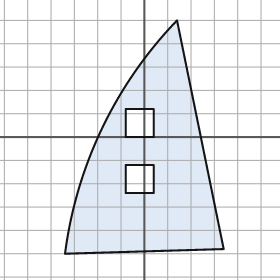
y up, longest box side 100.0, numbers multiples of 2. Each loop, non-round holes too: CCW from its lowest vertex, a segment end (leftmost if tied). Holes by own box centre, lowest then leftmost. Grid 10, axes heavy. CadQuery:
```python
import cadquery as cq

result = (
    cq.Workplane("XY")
    .moveTo(-34.0, -50.0)
    .lineTo(34.0, -48.0)
    .lineTo(14.0, 50.0)
    .threePointArc((-18.0, 4.0), (-34.0, -50.0))
    .close()
    .moveTo(-8.0, -24.0)
    .lineTo(4.0, -24.0)
    .lineTo(4.0, -12.0)
    .lineTo(-8.0, -12.0)
    .close()
    .moveTo(-8.0, 0.0)
    .lineTo(4.0, 0.0)
    .lineTo(4.0, 12.0)
    .lineTo(-8.0, 12.0)
    .close()
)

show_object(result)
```